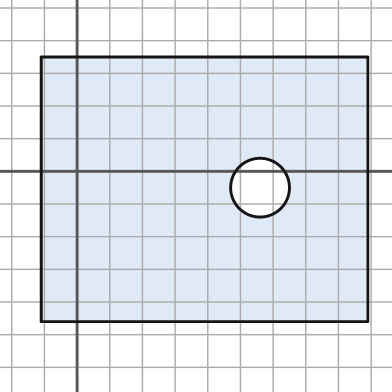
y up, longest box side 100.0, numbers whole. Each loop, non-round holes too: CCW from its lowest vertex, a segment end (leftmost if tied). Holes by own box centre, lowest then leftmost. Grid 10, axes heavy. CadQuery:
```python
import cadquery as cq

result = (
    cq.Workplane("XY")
    .moveTo(-11.0, -46.0)
    .lineTo(89.0, -46.0)
    .lineTo(89.0, 35.0)
    .lineTo(-11.0, 35.0)
    .close()
    .moveTo(56.0, -5.0)
    .circle(9.0)
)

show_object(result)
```